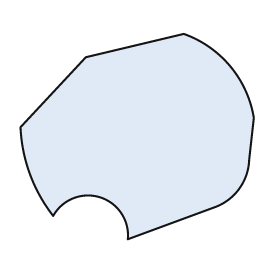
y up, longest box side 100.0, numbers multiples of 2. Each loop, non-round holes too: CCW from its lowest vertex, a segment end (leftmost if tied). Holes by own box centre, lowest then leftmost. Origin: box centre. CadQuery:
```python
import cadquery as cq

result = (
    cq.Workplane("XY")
    .moveTo(-4.0, -44.0)
    .lineTo(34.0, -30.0)
    .threePointArc((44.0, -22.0), (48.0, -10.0))
    .lineTo(50.0, 8.0)
    .threePointArc((40.0, 30.0), (20.0, 44.0))
    .lineTo(-22.0, 34.0)
    .lineTo(-50.0, 4.0)
    .threePointArc((-46.0, -16.0), (-36.0, -34.0))
    .threePointArc((-16.0, -26.0), (-4.0, -44.0))
    .close()
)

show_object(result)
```